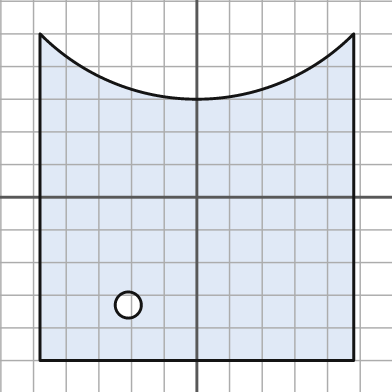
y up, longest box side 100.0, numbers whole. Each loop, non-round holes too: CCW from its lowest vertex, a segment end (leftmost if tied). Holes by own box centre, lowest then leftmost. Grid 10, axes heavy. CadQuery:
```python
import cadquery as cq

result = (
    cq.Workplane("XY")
    .moveTo(-48.0, -50.0)
    .lineTo(48.0, -50.0)
    .lineTo(48.0, 50.0)
    .threePointArc((0.0, 30.0), (-48.0, 50.0))
    .close()
    .moveTo(-21.0, -33.0)
    .circle(4.0)
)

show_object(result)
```